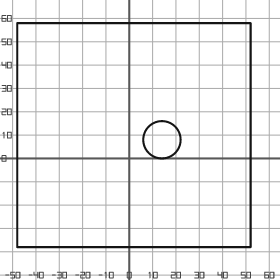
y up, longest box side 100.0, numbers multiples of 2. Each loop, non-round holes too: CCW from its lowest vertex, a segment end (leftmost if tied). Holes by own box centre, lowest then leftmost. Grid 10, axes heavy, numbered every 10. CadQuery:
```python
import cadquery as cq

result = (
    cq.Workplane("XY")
    .moveTo(-48.0, -38.0)
    .lineTo(52.0, -38.0)
    .lineTo(52.0, 58.0)
    .lineTo(-48.0, 58.0)
    .close()
    .moveTo(14.0, 8.0)
    .circle(8.0)
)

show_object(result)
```